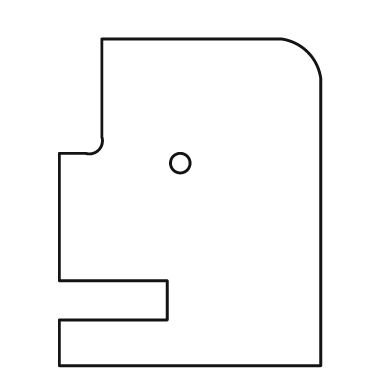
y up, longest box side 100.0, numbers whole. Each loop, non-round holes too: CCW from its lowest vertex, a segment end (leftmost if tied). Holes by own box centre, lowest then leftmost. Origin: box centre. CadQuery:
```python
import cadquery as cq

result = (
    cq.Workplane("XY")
    .moveTo(-40.0, -50.0)
    .lineTo(40.0, -50.0)
    .lineTo(40.0, 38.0)
    .threePointArc((36.0, 46.0), (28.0, 50.0))
    .lineTo(-27.0, 50.0)
    .lineTo(-27.0, 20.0)
    .threePointArc((-28.0, 16.0), (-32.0, 15.0))
    .lineTo(-40.0, 15.0)
    .lineTo(-40.0, -24.0)
    .lineTo(-7.0, -24.0)
    .lineTo(-7.0, -36.0)
    .lineTo(-40.0, -36.0)
    .close()
    .moveTo(-3.0, 12.0)
    .circle(3.0)
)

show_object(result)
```